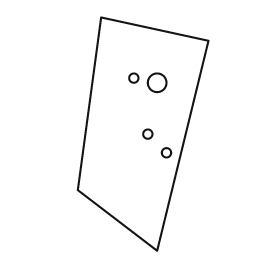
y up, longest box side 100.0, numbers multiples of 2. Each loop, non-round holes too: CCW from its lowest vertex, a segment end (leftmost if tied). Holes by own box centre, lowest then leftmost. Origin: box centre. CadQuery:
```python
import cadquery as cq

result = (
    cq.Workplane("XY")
    .moveTo(6.0, -50.0)
    .lineTo(28.0, 40.0)
    .lineTo(-18.0, 50.0)
    .lineTo(-28.0, -24.0)
    .close()
    .moveTo(10.0, -8.0)
    .circle(2.0)
    .moveTo(2.0, 0.0)
    .circle(2.0)
    .moveTo(6.0, 22.0)
    .circle(4.0)
    .moveTo(-4.0, 24.0)
    .circle(2.0)
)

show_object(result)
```